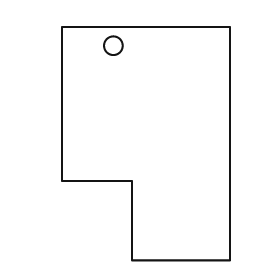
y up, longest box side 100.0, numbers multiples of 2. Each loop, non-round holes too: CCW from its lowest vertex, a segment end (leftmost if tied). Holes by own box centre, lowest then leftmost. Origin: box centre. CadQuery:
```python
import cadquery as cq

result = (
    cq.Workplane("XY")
    .moveTo(-6.0, -50.0)
    .lineTo(36.0, -50.0)
    .lineTo(36.0, 50.0)
    .lineTo(-36.0, 50.0)
    .lineTo(-36.0, -16.0)
    .lineTo(-6.0, -16.0)
    .close()
    .moveTo(-14.0, 42.0)
    .circle(4.0)
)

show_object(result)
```